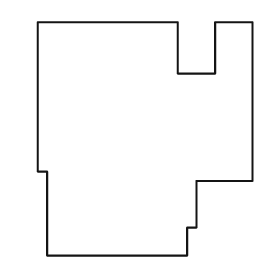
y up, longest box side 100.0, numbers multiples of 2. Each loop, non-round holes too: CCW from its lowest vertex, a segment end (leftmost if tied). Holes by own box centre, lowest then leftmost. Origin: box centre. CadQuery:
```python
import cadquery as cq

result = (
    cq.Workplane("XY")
    .moveTo(-42.0, -50.0)
    .lineTo(18.0, -50.0)
    .lineTo(18.0, -38.0)
    .lineTo(22.0, -38.0)
    .lineTo(22.0, -18.0)
    .lineTo(46.0, -18.0)
    .lineTo(46.0, 50.0)
    .lineTo(30.0, 50.0)
    .lineTo(30.0, 28.0)
    .lineTo(14.0, 28.0)
    .lineTo(14.0, 50.0)
    .lineTo(-46.0, 50.0)
    .lineTo(-46.0, -14.0)
    .lineTo(-42.0, -14.0)
    .close()
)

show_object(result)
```